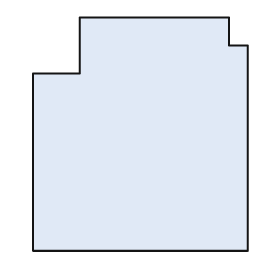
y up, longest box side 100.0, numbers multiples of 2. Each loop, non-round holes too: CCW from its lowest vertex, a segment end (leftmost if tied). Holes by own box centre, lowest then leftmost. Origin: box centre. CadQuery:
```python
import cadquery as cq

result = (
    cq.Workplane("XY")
    .moveTo(-46.0, -50.0)
    .lineTo(46.0, -50.0)
    .lineTo(46.0, 38.0)
    .lineTo(38.0, 38.0)
    .lineTo(38.0, 50.0)
    .lineTo(-26.0, 50.0)
    .lineTo(-26.0, 26.0)
    .lineTo(-46.0, 26.0)
    .close()
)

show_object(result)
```